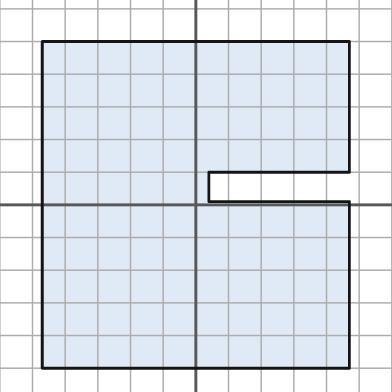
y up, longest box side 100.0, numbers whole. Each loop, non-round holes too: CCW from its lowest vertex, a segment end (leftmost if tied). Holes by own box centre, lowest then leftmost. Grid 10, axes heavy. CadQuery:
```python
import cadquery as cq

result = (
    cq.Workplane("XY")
    .moveTo(-47.0, -50.0)
    .lineTo(47.0, -50.0)
    .lineTo(47.0, 1.0)
    .lineTo(4.0, 1.0)
    .lineTo(4.0, 10.0)
    .lineTo(47.0, 10.0)
    .lineTo(47.0, 50.0)
    .lineTo(-47.0, 50.0)
    .close()
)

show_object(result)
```